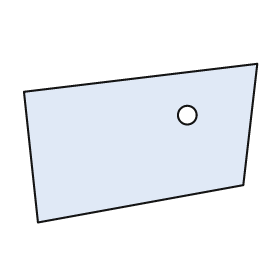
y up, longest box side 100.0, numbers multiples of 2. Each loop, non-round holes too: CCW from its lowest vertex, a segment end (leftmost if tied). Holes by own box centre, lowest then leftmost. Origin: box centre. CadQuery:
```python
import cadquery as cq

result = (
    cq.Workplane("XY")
    .moveTo(-44.0, -34.0)
    .lineTo(44.0, -18.0)
    .lineTo(50.0, 34.0)
    .lineTo(-50.0, 22.0)
    .close()
    .moveTo(20.0, 12.0)
    .circle(4.0)
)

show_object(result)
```